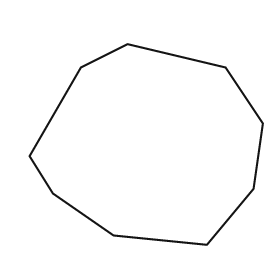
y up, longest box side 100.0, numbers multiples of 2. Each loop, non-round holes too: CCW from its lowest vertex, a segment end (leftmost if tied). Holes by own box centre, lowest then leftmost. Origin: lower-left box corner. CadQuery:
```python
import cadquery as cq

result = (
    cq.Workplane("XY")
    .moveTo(76.0, 0.0)
    .lineTo(96.0, 24.0)
    .lineTo(100.0, 52.0)
    .lineTo(84.0, 76.0)
    .lineTo(42.0, 86.0)
    .lineTo(22.0, 76.0)
    .lineTo(0.0, 38.0)
    .lineTo(10.0, 22.0)
    .lineTo(36.0, 4.0)
    .close()
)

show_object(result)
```